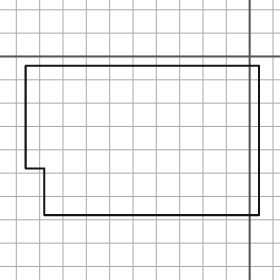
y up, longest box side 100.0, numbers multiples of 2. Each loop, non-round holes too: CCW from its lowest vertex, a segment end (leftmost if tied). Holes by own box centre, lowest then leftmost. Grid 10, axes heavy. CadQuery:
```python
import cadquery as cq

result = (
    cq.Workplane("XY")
    .moveTo(-88.0, -68.0)
    .lineTo(4.0, -68.0)
    .lineTo(4.0, -4.0)
    .lineTo(-96.0, -4.0)
    .lineTo(-96.0, -48.0)
    .lineTo(-88.0, -48.0)
    .close()
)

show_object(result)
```